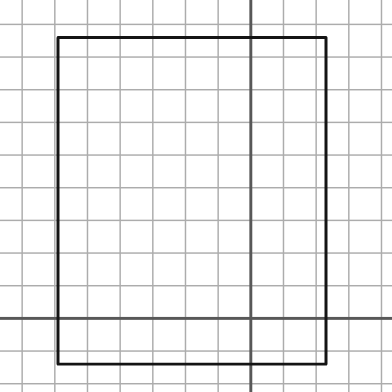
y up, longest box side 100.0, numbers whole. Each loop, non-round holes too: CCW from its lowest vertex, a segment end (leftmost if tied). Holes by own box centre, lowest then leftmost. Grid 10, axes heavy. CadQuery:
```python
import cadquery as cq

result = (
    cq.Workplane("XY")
    .moveTo(-59.0, -14.0)
    .lineTo(23.0, -14.0)
    .lineTo(23.0, 86.0)
    .lineTo(-59.0, 86.0)
    .close()
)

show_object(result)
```